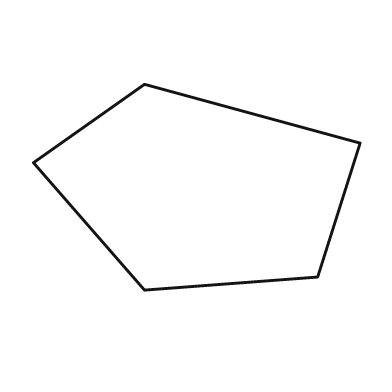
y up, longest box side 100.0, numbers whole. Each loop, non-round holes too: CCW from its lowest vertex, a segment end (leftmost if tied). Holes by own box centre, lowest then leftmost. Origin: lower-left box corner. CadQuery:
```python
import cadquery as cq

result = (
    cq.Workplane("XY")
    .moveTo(34.0, 0.0)
    .lineTo(87.0, 4.0)
    .lineTo(100.0, 45.0)
    .lineTo(34.0, 63.0)
    .lineTo(0.0, 39.0)
    .close()
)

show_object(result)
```